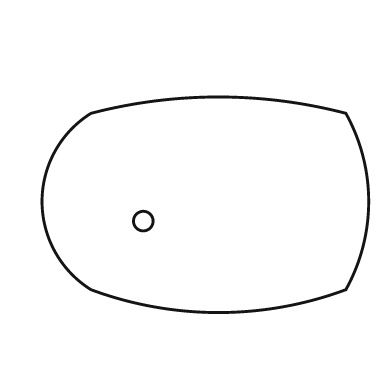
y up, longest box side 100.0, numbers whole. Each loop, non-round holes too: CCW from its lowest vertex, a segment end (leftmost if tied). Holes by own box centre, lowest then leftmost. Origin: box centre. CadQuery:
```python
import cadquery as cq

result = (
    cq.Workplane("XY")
    .moveTo(-35.0, -26.0)
    .threePointArc((4.0, -33.0), (43.0, -26.0))
    .threePointArc((50.0, 1.0), (43.0, 28.0))
    .threePointArc((4.0, 33.0), (-35.0, 28.0))
    .threePointArc((-50.0, 1.0), (-35.0, -26.0))
    .close()
    .moveTo(-19.0, -5.0)
    .circle(3.0)
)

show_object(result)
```